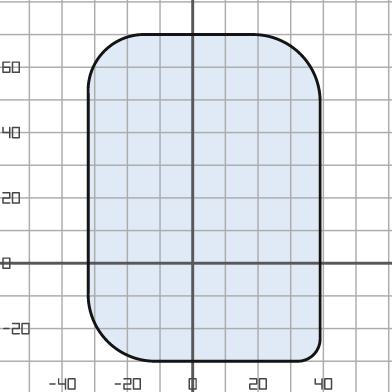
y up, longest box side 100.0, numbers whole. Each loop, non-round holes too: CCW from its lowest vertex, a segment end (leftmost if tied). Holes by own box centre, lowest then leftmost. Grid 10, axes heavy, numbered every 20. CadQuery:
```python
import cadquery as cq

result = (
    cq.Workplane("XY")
    .moveTo(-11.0, -30.0)
    .lineTo(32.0, -30.0)
    .threePointArc((37.0, -28.0), (39.0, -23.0))
    .lineTo(39.0, 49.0)
    .threePointArc((33.0, 64.0), (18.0, 70.0))
    .lineTo(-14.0, 70.0)
    .threePointArc((-27.0, 65.0), (-32.0, 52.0))
    .lineTo(-32.0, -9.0)
    .threePointArc((-26.0, -24.0), (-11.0, -30.0))
    .close()
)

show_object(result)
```